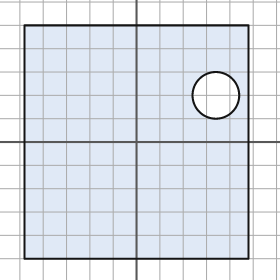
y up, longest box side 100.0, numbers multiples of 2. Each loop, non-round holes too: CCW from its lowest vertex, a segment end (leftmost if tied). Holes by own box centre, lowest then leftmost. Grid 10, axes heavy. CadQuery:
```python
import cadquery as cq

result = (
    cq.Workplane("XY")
    .moveTo(-48.0, -50.0)
    .lineTo(48.0, -50.0)
    .lineTo(48.0, 50.0)
    .lineTo(-48.0, 50.0)
    .close()
    .moveTo(34.0, 20.0)
    .circle(10.0)
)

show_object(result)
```